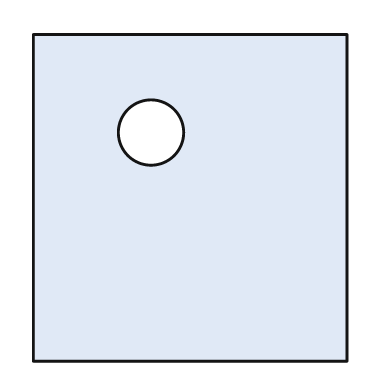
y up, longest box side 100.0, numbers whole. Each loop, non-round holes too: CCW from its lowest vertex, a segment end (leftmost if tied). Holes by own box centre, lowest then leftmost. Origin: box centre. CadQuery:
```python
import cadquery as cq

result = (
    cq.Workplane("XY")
    .moveTo(-48.0, -50.0)
    .lineTo(48.0, -50.0)
    .lineTo(48.0, 50.0)
    .lineTo(-48.0, 50.0)
    .close()
    .moveTo(-12.0, 20.0)
    .circle(10.0)
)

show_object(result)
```